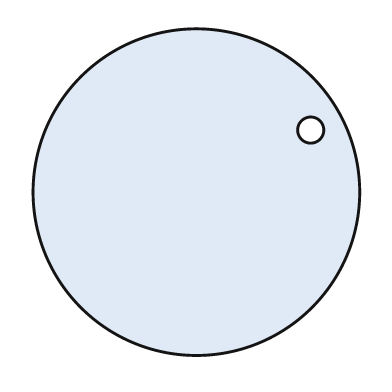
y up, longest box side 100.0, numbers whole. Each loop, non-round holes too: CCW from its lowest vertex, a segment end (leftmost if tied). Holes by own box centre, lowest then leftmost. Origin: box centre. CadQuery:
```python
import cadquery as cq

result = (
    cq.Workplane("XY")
    .moveTo(0.0, 0.0)
    .circle(50.0)
    .moveTo(35.0, 19.0)
    .circle(4.0)
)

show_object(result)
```